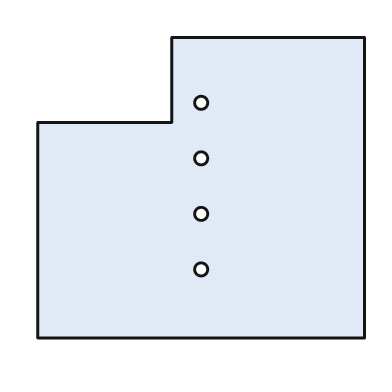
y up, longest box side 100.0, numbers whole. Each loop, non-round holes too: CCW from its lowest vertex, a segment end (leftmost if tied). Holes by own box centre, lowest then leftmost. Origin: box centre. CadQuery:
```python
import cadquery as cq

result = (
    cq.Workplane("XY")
    .moveTo(-50.0, -46.0)
    .lineTo(50.0, -46.0)
    .lineTo(50.0, 46.0)
    .lineTo(-9.0, 46.0)
    .lineTo(-9.0, 20.0)
    .lineTo(-50.0, 20.0)
    .close()
    .moveTo(0.0, -25.0)
    .circle(2.0)
    .moveTo(0.0, -8.0)
    .circle(2.0)
    .moveTo(0.0, 9.0)
    .circle(2.0)
    .moveTo(0.0, 26.0)
    .circle(2.0)
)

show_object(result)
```